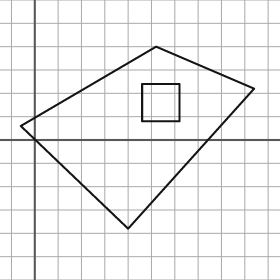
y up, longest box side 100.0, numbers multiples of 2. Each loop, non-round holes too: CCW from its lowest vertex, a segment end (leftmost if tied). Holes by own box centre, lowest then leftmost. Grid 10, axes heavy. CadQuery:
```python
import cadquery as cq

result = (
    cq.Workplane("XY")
    .moveTo(40.0, -38.0)
    .lineTo(94.0, 22.0)
    .lineTo(52.0, 40.0)
    .lineTo(-6.0, 6.0)
    .close()
    .moveTo(46.0, 8.0)
    .lineTo(62.0, 8.0)
    .lineTo(62.0, 24.0)
    .lineTo(46.0, 24.0)
    .close()
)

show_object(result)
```